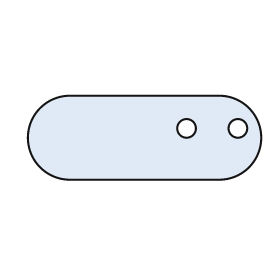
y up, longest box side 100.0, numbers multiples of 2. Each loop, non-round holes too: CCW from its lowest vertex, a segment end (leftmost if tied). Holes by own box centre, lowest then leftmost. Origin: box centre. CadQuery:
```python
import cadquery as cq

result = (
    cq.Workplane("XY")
    .moveTo(-32.0, -18.0)
    .lineTo(32.0, -18.0)
    .threePointArc((50.0, 0.0), (32.0, 18.0))
    .lineTo(-32.0, 18.0)
    .threePointArc((-50.0, 0.0), (-32.0, -18.0))
    .close()
    .moveTo(18.0, 4.0)
    .circle(4.0)
    .moveTo(40.0, 4.0)
    .circle(4.0)
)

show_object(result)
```